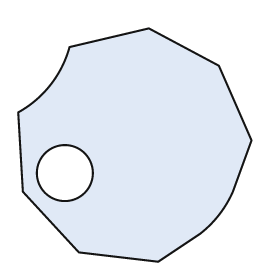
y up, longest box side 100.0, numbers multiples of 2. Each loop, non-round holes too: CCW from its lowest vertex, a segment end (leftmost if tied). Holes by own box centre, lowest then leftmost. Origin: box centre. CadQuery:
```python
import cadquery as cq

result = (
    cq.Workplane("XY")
    .moveTo(10.0, -50.0)
    .lineTo(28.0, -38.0)
    .threePointArc((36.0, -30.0), (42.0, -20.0))
    .lineTo(50.0, 2.0)
    .lineTo(36.0, 34.0)
    .lineTo(6.0, 50.0)
    .lineTo(-28.0, 42.0)
    .threePointArc((-36.0, 26.0), (-50.0, 14.0))
    .lineTo(-48.0, -20.0)
    .lineTo(-24.0, -46.0)
    .close()
    .moveTo(-30.0, -12.0)
    .circle(12.0)
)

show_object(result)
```